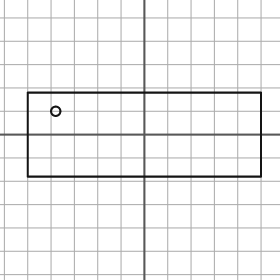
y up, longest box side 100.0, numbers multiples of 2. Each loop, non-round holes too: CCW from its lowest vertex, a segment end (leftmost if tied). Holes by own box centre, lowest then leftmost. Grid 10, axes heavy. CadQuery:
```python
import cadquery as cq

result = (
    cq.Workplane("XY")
    .moveTo(-50.0, -18.0)
    .lineTo(50.0, -18.0)
    .lineTo(50.0, 18.0)
    .lineTo(-50.0, 18.0)
    .close()
    .moveTo(-38.0, 10.0)
    .circle(2.0)
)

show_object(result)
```